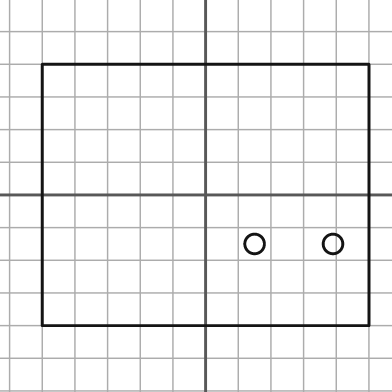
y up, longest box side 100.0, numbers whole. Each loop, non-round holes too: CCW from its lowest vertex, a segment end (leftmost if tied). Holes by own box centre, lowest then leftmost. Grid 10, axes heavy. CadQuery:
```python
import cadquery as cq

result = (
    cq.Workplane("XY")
    .moveTo(-50.0, -40.0)
    .lineTo(50.0, -40.0)
    .lineTo(50.0, 40.0)
    .lineTo(-50.0, 40.0)
    .close()
    .moveTo(15.0, -15.0)
    .circle(3.0)
    .moveTo(39.0, -15.0)
    .circle(3.0)
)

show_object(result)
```